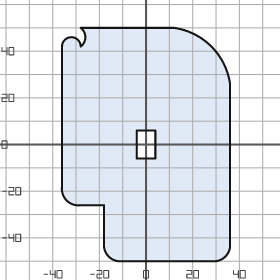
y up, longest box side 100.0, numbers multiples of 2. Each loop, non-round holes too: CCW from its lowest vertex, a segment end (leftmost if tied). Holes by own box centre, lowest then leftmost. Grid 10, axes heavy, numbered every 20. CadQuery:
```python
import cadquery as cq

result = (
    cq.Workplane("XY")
    .moveTo(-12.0, -50.0)
    .lineTo(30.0, -50.0)
    .threePointArc((34.0, -48.0), (36.0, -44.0))
    .lineTo(36.0, 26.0)
    .threePointArc((28.0, 42.0), (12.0, 50.0))
    .lineTo(-28.0, 50.0)
    .threePointArc((-26.0, 46.0), (-28.0, 42.0))
    .threePointArc((-32.0, 46.0), (-36.0, 42.0))
    .lineTo(-36.0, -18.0)
    .threePointArc((-34.0, -24.0), (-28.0, -26.0))
    .lineTo(-18.0, -26.0)
    .lineTo(-18.0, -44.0)
    .threePointArc((-16.0, -48.0), (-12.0, -50.0))
    .close()
    .moveTo(-4.0, -6.0)
    .lineTo(4.0, -6.0)
    .lineTo(4.0, 6.0)
    .lineTo(-4.0, 6.0)
    .close()
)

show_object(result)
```